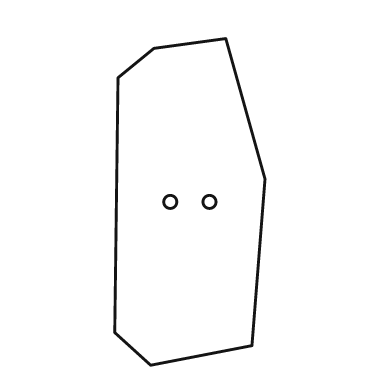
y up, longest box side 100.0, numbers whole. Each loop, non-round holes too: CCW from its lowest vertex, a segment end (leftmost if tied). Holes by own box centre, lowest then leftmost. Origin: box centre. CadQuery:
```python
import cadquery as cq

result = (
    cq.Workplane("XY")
    .moveTo(-12.0, -50.0)
    .lineTo(19.0, -44.0)
    .lineTo(23.0, 7.0)
    .lineTo(11.0, 50.0)
    .lineTo(-11.0, 47.0)
    .lineTo(-22.0, 38.0)
    .lineTo(-23.0, -40.0)
    .close()
    .moveTo(-6.0, 0.0)
    .circle(2.0)
    .moveTo(6.0, 0.0)
    .circle(2.0)
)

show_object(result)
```